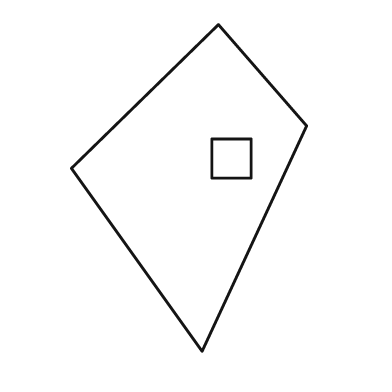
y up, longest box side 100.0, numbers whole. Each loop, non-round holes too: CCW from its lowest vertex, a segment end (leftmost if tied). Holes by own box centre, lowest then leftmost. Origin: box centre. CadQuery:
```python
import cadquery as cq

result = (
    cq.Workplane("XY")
    .moveTo(4.0, -50.0)
    .lineTo(36.0, 19.0)
    .lineTo(9.0, 50.0)
    .lineTo(-36.0, 6.0)
    .close()
    .moveTo(7.0, 3.0)
    .lineTo(19.0, 3.0)
    .lineTo(19.0, 15.0)
    .lineTo(7.0, 15.0)
    .close()
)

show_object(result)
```